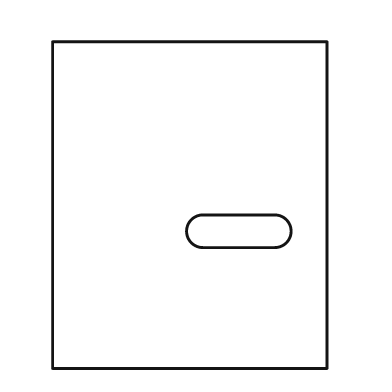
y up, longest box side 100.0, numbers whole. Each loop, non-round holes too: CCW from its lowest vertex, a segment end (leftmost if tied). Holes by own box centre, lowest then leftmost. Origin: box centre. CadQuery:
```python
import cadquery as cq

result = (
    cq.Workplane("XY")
    .moveTo(-42.0, -50.0)
    .lineTo(42.0, -50.0)
    .lineTo(42.0, 50.0)
    .lineTo(-42.0, 50.0)
    .close()
    .moveTo(4.0, -13.0)
    .lineTo(26.0, -13.0)
    .threePointArc((31.0, -8.0), (26.0, -3.0))
    .lineTo(4.0, -3.0)
    .threePointArc((-1.0, -8.0), (4.0, -13.0))
    .close()
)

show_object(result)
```